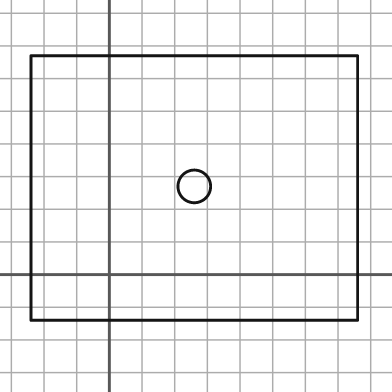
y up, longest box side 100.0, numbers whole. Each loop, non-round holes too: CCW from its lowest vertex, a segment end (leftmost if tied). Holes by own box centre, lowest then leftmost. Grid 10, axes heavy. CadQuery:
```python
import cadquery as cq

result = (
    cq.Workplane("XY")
    .moveTo(-24.0, -14.0)
    .lineTo(76.0, -14.0)
    .lineTo(76.0, 67.0)
    .lineTo(-24.0, 67.0)
    .close()
    .moveTo(26.0, 27.0)
    .circle(5.0)
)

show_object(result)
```